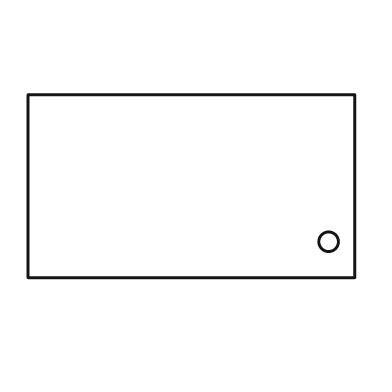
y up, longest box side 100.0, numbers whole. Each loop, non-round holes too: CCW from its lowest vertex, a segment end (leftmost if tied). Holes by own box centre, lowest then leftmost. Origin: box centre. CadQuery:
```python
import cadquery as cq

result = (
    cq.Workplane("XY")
    .moveTo(-50.0, -28.0)
    .lineTo(50.0, -28.0)
    .lineTo(50.0, 28.0)
    .lineTo(-50.0, 28.0)
    .close()
    .moveTo(42.0, -17.0)
    .circle(3.0)
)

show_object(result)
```